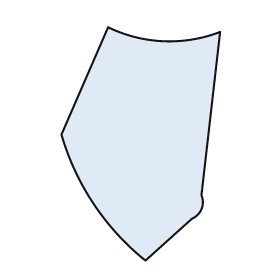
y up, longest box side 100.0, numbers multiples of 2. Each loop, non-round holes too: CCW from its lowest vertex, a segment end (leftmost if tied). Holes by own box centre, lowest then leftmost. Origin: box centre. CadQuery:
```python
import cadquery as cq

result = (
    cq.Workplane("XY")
    .moveTo(2.0, -50.0)
    .lineTo(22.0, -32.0)
    .threePointArc((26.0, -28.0), (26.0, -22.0))
    .lineTo(34.0, 48.0)
    .threePointArc((10.0, 44.0), (-14.0, 50.0))
    .lineTo(-34.0, 4.0)
    .threePointArc((-20.0, -26.0), (2.0, -50.0))
    .close()
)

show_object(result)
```